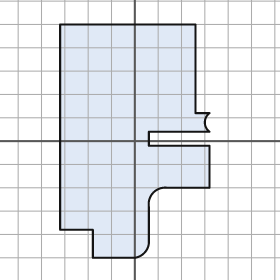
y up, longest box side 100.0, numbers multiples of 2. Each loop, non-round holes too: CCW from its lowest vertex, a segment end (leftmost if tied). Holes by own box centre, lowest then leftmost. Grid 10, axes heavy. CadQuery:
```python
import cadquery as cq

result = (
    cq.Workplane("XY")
    .moveTo(-18.0, -50.0)
    .lineTo(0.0, -50.0)
    .threePointArc((4.0, -48.0), (6.0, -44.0))
    .lineTo(6.0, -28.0)
    .threePointArc((8.0, -22.0), (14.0, -20.0))
    .lineTo(32.0, -20.0)
    .lineTo(32.0, -2.0)
    .lineTo(6.0, -2.0)
    .lineTo(6.0, 4.0)
    .lineTo(32.0, 4.0)
    .threePointArc((30.0, 8.0), (32.0, 12.0))
    .lineTo(26.0, 12.0)
    .lineTo(26.0, 50.0)
    .lineTo(-32.0, 50.0)
    .lineTo(-32.0, -38.0)
    .lineTo(-18.0, -38.0)
    .close()
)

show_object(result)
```